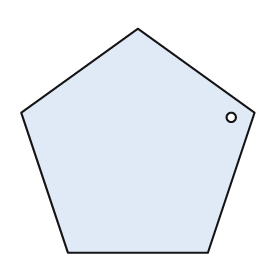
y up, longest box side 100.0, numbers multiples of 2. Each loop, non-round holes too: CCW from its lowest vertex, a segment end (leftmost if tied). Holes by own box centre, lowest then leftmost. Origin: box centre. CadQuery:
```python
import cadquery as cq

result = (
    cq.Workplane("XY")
    .moveTo(-30.0, -48.0)
    .lineTo(30.0, -48.0)
    .lineTo(50.0, 12.0)
    .lineTo(0.0, 48.0)
    .lineTo(-50.0, 12.0)
    .close()
    .moveTo(40.0, 10.0)
    .circle(2.0)
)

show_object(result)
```